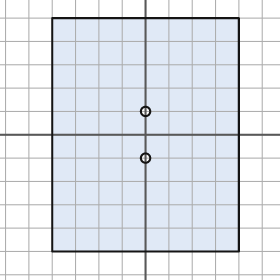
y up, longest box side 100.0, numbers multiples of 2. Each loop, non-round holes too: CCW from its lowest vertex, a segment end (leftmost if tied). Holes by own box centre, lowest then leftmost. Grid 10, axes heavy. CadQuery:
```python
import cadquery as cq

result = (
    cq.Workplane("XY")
    .moveTo(-40.0, -50.0)
    .lineTo(40.0, -50.0)
    .lineTo(40.0, 50.0)
    .lineTo(-40.0, 50.0)
    .close()
    .moveTo(0.0, -10.0)
    .circle(2.0)
    .moveTo(0.0, 10.0)
    .circle(2.0)
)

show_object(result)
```